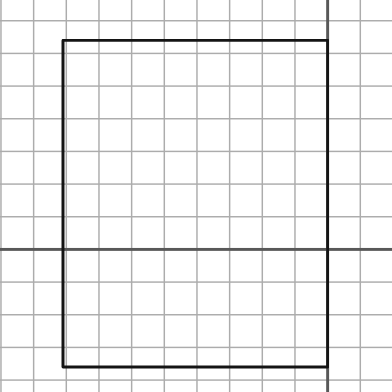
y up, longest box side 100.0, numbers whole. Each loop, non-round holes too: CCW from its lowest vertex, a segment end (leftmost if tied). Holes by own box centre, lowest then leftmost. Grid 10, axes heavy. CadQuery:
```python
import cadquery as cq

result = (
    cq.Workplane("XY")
    .moveTo(-81.0, -36.0)
    .lineTo(0.0, -36.0)
    .lineTo(0.0, 64.0)
    .lineTo(-81.0, 64.0)
    .close()
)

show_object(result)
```